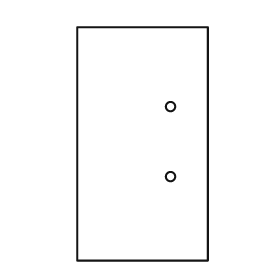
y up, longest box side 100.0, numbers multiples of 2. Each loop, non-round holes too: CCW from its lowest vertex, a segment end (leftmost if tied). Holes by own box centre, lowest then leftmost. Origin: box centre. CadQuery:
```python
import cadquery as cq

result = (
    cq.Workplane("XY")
    .moveTo(-28.0, -50.0)
    .lineTo(28.0, -50.0)
    .lineTo(28.0, 50.0)
    .lineTo(-28.0, 50.0)
    .close()
    .moveTo(12.0, -14.0)
    .circle(2.0)
    .moveTo(12.0, 16.0)
    .circle(2.0)
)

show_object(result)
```